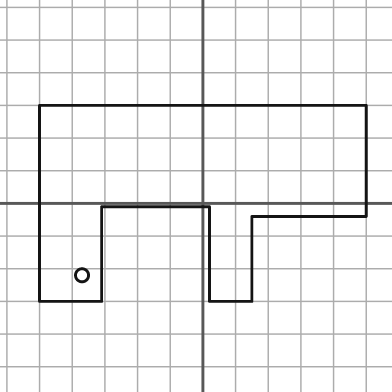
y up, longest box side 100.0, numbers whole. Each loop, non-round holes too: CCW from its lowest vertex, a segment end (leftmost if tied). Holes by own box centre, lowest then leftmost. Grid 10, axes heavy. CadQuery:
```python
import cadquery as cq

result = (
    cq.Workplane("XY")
    .moveTo(-50.0, -30.0)
    .lineTo(-31.0, -30.0)
    .lineTo(-31.0, -1.0)
    .lineTo(2.0, -1.0)
    .lineTo(2.0, -30.0)
    .lineTo(15.0, -30.0)
    .lineTo(15.0, -4.0)
    .lineTo(50.0, -4.0)
    .lineTo(50.0, 30.0)
    .lineTo(-50.0, 30.0)
    .close()
    .moveTo(-37.0, -22.0)
    .circle(2.0)
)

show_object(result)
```